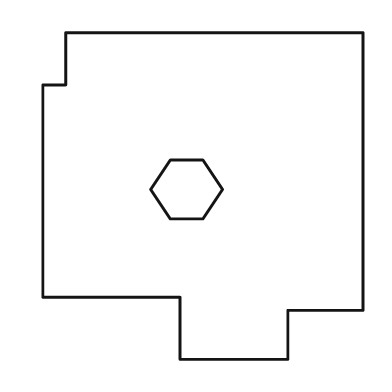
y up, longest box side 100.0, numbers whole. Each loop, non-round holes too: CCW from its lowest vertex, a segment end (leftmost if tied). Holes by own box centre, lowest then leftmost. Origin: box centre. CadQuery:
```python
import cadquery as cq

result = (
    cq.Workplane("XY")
    .moveTo(-7.0, -50.0)
    .lineTo(26.0, -50.0)
    .lineTo(26.0, -35.0)
    .lineTo(49.0, -35.0)
    .lineTo(49.0, 50.0)
    .lineTo(-42.0, 50.0)
    .lineTo(-42.0, 34.0)
    .lineTo(-49.0, 34.0)
    .lineTo(-49.0, -31.0)
    .lineTo(-7.0, -31.0)
    .close()
    .moveTo(-10.0, -7.0)
    .lineTo(0.0, -7.0)
    .lineTo(6.0, 2.0)
    .lineTo(0.0, 11.0)
    .lineTo(-10.0, 11.0)
    .lineTo(-16.0, 2.0)
    .close()
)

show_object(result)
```